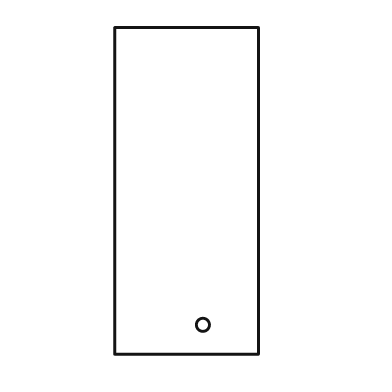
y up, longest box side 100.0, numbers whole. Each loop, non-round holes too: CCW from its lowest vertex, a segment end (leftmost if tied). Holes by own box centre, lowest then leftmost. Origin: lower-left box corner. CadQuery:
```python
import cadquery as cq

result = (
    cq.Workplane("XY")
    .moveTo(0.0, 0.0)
    .lineTo(44.0, 0.0)
    .lineTo(44.0, 100.0)
    .lineTo(0.0, 100.0)
    .close()
    .moveTo(27.0, 9.0)
    .circle(2.0)
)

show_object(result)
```